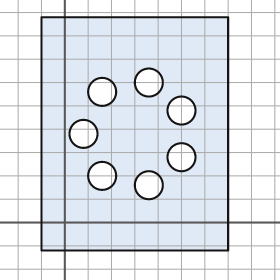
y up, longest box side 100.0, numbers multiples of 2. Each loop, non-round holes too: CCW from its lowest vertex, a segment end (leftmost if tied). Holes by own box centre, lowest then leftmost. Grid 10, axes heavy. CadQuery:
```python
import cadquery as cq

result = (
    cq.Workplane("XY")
    .moveTo(-10.0, -12.0)
    .lineTo(70.0, -12.0)
    .lineTo(70.0, 88.0)
    .lineTo(-10.0, 88.0)
    .close()
    .moveTo(36.0, 16.0)
    .circle(6.0)
    .moveTo(16.0, 20.0)
    .circle(6.0)
    .moveTo(50.0, 28.0)
    .circle(6.0)
    .moveTo(8.0, 38.0)
    .circle(6.0)
    .moveTo(50.0, 48.0)
    .circle(6.0)
    .moveTo(16.0, 56.0)
    .circle(6.0)
    .moveTo(36.0, 60.0)
    .circle(6.0)
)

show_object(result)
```